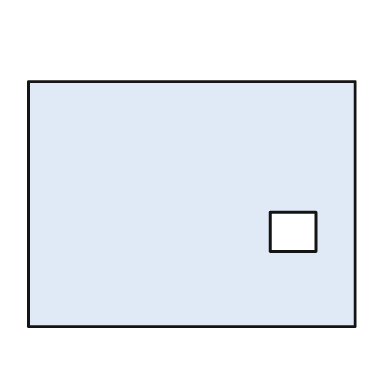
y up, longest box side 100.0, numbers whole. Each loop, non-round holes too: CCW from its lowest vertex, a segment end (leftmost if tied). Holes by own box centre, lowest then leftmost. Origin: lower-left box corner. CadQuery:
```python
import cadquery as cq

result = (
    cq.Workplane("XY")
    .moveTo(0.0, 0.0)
    .lineTo(100.0, 0.0)
    .lineTo(100.0, 75.0)
    .lineTo(0.0, 75.0)
    .close()
    .moveTo(74.0, 23.0)
    .lineTo(88.0, 23.0)
    .lineTo(88.0, 35.0)
    .lineTo(74.0, 35.0)
    .close()
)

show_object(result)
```